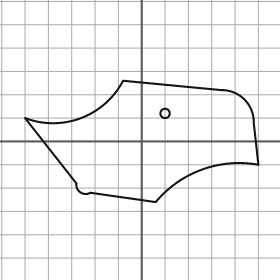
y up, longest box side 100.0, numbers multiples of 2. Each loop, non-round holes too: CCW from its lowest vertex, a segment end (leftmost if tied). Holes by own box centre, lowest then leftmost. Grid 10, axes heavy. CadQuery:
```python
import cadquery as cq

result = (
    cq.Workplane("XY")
    .moveTo(6.0, -26.0)
    .threePointArc((26.0, -12.0), (50.0, -10.0))
    .lineTo(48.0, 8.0)
    .threePointArc((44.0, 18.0), (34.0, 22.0))
    .lineTo(-8.0, 26.0)
    .threePointArc((-26.0, 10.0), (-50.0, 10.0))
    .lineTo(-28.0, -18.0)
    .threePointArc((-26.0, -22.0), (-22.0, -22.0))
    .close()
    .moveTo(10.0, 12.0)
    .circle(2.0)
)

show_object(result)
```